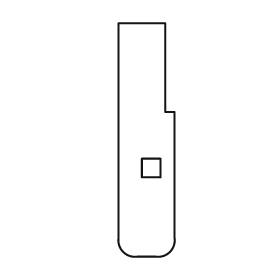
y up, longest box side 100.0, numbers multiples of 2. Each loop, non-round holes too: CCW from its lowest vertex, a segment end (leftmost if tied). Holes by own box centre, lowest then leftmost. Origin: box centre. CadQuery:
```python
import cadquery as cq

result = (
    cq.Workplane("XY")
    .moveTo(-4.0, -50.0)
    .lineTo(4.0, -50.0)
    .threePointArc((10.0, -48.0), (12.0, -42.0))
    .lineTo(12.0, 12.0)
    .lineTo(8.0, 12.0)
    .lineTo(8.0, 50.0)
    .lineTo(-12.0, 50.0)
    .lineTo(-12.0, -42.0)
    .threePointArc((-10.0, -48.0), (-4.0, -50.0))
    .close()
    .moveTo(-2.0, -16.0)
    .lineTo(6.0, -16.0)
    .lineTo(6.0, -8.0)
    .lineTo(-2.0, -8.0)
    .close()
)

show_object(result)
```